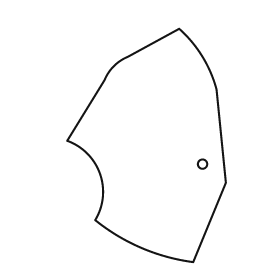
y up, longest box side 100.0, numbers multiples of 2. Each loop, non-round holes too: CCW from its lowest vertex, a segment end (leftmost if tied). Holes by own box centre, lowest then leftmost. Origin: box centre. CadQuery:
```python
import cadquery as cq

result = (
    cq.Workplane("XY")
    .moveTo(20.0, -50.0)
    .lineTo(34.0, -16.0)
    .lineTo(30.0, 24.0)
    .threePointArc((24.0, 38.0), (14.0, 50.0))
    .lineTo(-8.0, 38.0)
    .threePointArc((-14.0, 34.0), (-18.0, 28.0))
    .lineTo(-34.0, 2.0)
    .threePointArc((-20.0, -12.0), (-22.0, -32.0))
    .threePointArc((-2.0, -44.0), (20.0, -50.0))
    .close()
    .moveTo(24.0, -8.0)
    .circle(2.0)
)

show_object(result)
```